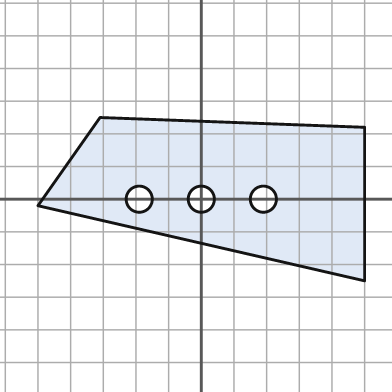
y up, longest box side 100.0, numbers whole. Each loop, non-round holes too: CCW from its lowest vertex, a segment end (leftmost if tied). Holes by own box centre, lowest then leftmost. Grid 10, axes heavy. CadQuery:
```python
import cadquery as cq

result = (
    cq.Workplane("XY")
    .moveTo(50.0, -25.0)
    .lineTo(50.0, 22.0)
    .lineTo(-31.0, 25.0)
    .lineTo(-50.0, -2.0)
    .close()
    .moveTo(-19.0, 0.0)
    .circle(4.0)
    .moveTo(0.0, 0.0)
    .circle(4.0)
    .moveTo(19.0, 0.0)
    .circle(4.0)
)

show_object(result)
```